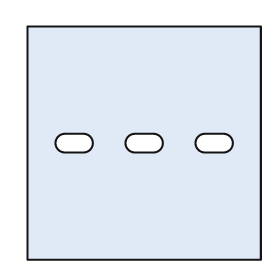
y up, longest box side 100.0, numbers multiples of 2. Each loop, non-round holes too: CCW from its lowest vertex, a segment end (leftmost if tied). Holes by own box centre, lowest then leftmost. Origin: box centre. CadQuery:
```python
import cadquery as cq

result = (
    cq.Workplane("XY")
    .moveTo(-50.0, -50.0)
    .lineTo(50.0, -50.0)
    .lineTo(50.0, 50.0)
    .lineTo(-50.0, 50.0)
    .close()
    .moveTo(-34.0, -4.0)
    .lineTo(-26.0, -4.0)
    .threePointArc((-22.0, 0.0), (-26.0, 4.0))
    .lineTo(-34.0, 4.0)
    .threePointArc((-38.0, 0.0), (-34.0, -4.0))
    .close()
    .moveTo(-4.0, -4.0)
    .lineTo(4.0, -4.0)
    .threePointArc((8.0, 0.0), (4.0, 4.0))
    .lineTo(-4.0, 4.0)
    .threePointArc((-8.0, 0.0), (-4.0, -4.0))
    .close()
    .moveTo(26.0, -4.0)
    .lineTo(34.0, -4.0)
    .threePointArc((38.0, 0.0), (34.0, 4.0))
    .lineTo(26.0, 4.0)
    .threePointArc((22.0, 0.0), (26.0, -4.0))
    .close()
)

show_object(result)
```